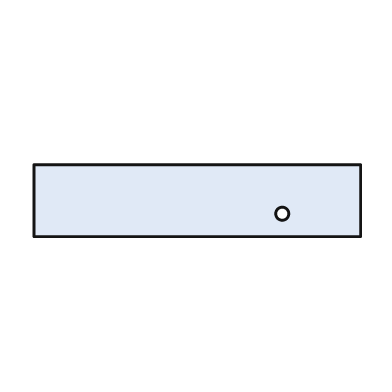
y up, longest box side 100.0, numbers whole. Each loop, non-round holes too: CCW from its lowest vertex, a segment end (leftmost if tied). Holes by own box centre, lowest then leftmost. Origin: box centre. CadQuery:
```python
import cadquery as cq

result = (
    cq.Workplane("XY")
    .moveTo(-50.0, -11.0)
    .lineTo(50.0, -11.0)
    .lineTo(50.0, 11.0)
    .lineTo(-50.0, 11.0)
    .close()
    .moveTo(26.0, -4.0)
    .circle(2.0)
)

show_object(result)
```